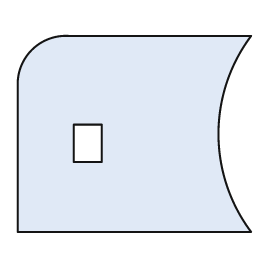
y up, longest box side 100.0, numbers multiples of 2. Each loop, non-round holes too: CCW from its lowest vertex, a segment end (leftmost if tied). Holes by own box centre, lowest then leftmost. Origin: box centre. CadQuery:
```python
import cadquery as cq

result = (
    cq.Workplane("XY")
    .moveTo(-50.0, -42.0)
    .lineTo(50.0, -42.0)
    .threePointArc((36.0, 0.0), (50.0, 42.0))
    .lineTo(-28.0, 42.0)
    .threePointArc((-44.0, 36.0), (-50.0, 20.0))
    .close()
    .moveTo(-26.0, -12.0)
    .lineTo(-14.0, -12.0)
    .lineTo(-14.0, 4.0)
    .lineTo(-26.0, 4.0)
    .close()
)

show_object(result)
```